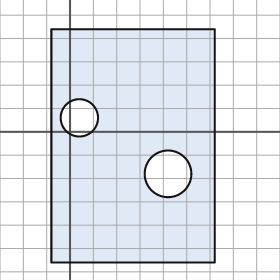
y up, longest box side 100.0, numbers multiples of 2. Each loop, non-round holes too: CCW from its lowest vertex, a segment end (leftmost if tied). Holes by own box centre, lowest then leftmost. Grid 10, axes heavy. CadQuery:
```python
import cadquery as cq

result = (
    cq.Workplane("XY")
    .moveTo(-8.0, -56.0)
    .lineTo(62.0, -56.0)
    .lineTo(62.0, 44.0)
    .lineTo(-8.0, 44.0)
    .close()
    .moveTo(42.0, -18.0)
    .circle(10.0)
    .moveTo(4.0, 6.0)
    .circle(8.0)
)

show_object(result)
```